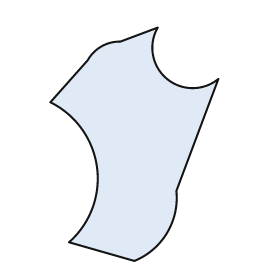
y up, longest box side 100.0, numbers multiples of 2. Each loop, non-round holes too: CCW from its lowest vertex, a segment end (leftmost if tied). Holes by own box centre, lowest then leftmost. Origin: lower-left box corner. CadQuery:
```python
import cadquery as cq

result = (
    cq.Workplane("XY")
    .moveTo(36.0, 0.0)
    .threePointArc((50.0, 12.0), (54.0, 30.0))
    .lineTo(72.0, 78.0)
    .threePointArc((50.0, 78.0), (46.0, 100.0))
    .lineTo(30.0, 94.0)
    .threePointArc((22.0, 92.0), (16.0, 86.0))
    .lineTo(0.0, 68.0)
    .threePointArc((20.0, 40.0), (8.0, 8.0))
    .close()
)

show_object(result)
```